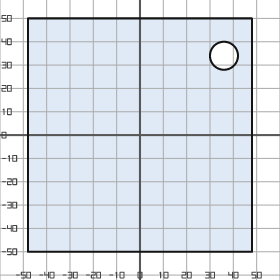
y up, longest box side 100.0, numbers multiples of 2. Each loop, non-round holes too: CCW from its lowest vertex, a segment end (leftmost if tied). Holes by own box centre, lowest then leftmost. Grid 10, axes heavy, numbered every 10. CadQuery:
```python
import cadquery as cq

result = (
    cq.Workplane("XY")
    .moveTo(-48.0, -50.0)
    .lineTo(48.0, -50.0)
    .lineTo(48.0, 50.0)
    .lineTo(-48.0, 50.0)
    .close()
    .moveTo(36.0, 34.0)
    .circle(6.0)
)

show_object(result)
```